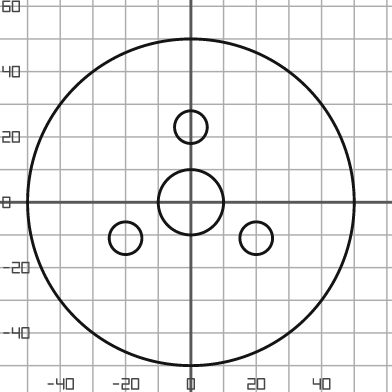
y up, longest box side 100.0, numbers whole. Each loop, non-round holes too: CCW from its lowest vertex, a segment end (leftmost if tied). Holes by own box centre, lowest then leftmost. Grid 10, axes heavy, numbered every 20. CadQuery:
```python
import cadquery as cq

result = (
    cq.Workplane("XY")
    .moveTo(0.0, 0.0)
    .circle(50.0)
    .moveTo(-20.0, -11.0)
    .circle(5.0)
    .moveTo(20.0, -11.0)
    .circle(5.0)
    .moveTo(0.0, 0.0)
    .circle(10.0)
    .moveTo(0.0, 23.0)
    .circle(5.0)
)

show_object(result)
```